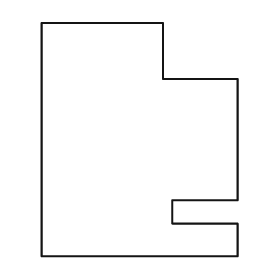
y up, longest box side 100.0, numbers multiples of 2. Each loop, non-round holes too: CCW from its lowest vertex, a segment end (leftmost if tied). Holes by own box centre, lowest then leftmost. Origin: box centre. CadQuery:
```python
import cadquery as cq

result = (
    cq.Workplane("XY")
    .moveTo(-42.0, -50.0)
    .lineTo(42.0, -50.0)
    .lineTo(42.0, -36.0)
    .lineTo(14.0, -36.0)
    .lineTo(14.0, -26.0)
    .lineTo(42.0, -26.0)
    .lineTo(42.0, 26.0)
    .lineTo(10.0, 26.0)
    .lineTo(10.0, 50.0)
    .lineTo(-42.0, 50.0)
    .close()
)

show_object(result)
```